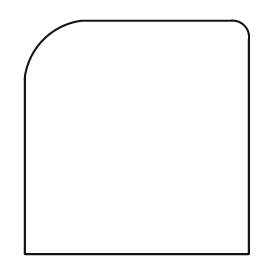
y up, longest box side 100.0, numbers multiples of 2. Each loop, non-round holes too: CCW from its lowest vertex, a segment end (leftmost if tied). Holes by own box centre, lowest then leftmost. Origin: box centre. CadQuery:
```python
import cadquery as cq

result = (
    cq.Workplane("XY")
    .moveTo(-48.0, -50.0)
    .lineTo(48.0, -50.0)
    .lineTo(48.0, 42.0)
    .threePointArc((46.0, 48.0), (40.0, 50.0))
    .lineTo(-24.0, 50.0)
    .threePointArc((-40.0, 42.0), (-48.0, 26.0))
    .close()
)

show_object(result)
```